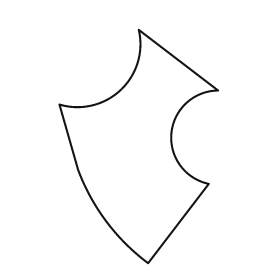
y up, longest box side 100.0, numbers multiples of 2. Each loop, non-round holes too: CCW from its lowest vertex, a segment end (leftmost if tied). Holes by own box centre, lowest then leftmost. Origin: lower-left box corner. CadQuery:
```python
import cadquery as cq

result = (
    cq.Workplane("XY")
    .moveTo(38.0, 0.0)
    .lineTo(64.0, 34.0)
    .threePointArc((48.0, 56.0), (68.0, 74.0))
    .lineTo(34.0, 100.0)
    .threePointArc((26.0, 74.0), (0.0, 68.0))
    .lineTo(8.0, 40.0)
    .threePointArc((20.0, 18.0), (38.0, 0.0))
    .close()
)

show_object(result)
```